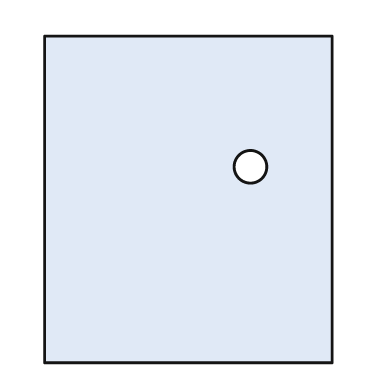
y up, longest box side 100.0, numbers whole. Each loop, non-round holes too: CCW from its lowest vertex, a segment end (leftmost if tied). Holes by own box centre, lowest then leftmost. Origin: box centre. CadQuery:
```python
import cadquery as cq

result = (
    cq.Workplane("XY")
    .moveTo(-44.0, -50.0)
    .lineTo(44.0, -50.0)
    .lineTo(44.0, 50.0)
    .lineTo(-44.0, 50.0)
    .close()
    .moveTo(19.0, 10.0)
    .circle(5.0)
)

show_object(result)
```